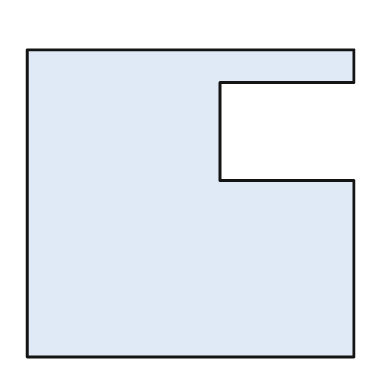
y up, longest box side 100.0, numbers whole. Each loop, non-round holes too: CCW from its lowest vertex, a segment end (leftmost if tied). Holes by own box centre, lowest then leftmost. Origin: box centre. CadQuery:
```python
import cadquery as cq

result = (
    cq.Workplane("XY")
    .moveTo(-50.0, -47.0)
    .lineTo(50.0, -47.0)
    .lineTo(50.0, 7.0)
    .lineTo(9.0, 7.0)
    .lineTo(9.0, 37.0)
    .lineTo(50.0, 37.0)
    .lineTo(50.0, 47.0)
    .lineTo(-50.0, 47.0)
    .close()
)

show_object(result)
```